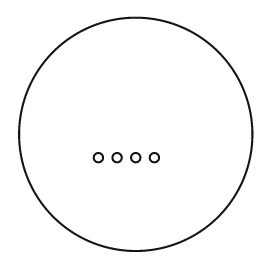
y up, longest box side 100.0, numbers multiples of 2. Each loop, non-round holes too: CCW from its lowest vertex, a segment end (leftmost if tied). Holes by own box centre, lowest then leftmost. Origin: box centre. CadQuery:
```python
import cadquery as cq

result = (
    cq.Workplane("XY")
    .moveTo(0.0, 0.0)
    .circle(50.0)
    .moveTo(-16.0, -10.0)
    .circle(2.0)
    .moveTo(-8.0, -10.0)
    .circle(2.0)
    .moveTo(0.0, -10.0)
    .circle(2.0)
    .moveTo(8.0, -10.0)
    .circle(2.0)
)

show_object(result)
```